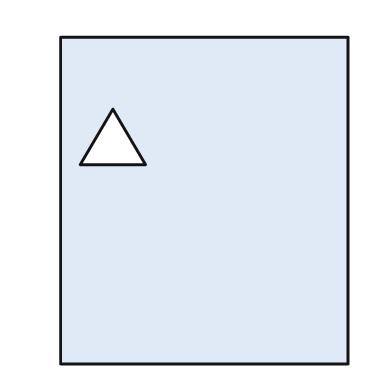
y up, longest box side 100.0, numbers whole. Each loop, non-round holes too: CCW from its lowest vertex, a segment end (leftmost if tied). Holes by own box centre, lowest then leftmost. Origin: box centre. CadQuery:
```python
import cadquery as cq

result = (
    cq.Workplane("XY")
    .moveTo(-44.0, -50.0)
    .lineTo(44.0, -50.0)
    .lineTo(44.0, 50.0)
    .lineTo(-44.0, 50.0)
    .close()
    .moveTo(-38.0, 11.0)
    .lineTo(-18.0, 11.0)
    .lineTo(-28.0, 28.0)
    .close()
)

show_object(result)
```